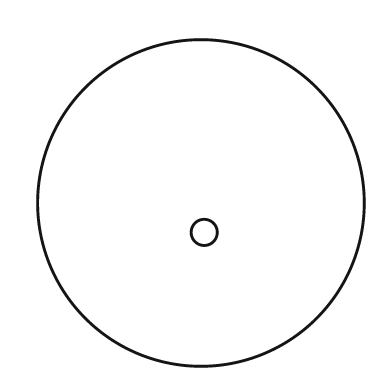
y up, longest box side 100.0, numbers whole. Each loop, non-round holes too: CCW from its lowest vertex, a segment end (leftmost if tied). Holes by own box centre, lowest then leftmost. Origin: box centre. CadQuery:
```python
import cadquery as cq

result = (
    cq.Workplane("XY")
    .moveTo(0.0, 0.0)
    .circle(50.0)
    .moveTo(1.0, -9.0)
    .circle(4.0)
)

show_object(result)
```